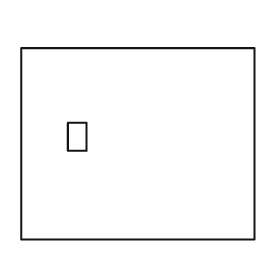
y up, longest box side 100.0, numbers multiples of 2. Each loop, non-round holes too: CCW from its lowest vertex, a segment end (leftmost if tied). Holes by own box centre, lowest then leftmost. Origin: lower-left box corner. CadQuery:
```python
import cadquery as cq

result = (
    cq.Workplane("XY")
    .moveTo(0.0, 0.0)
    .lineTo(100.0, 0.0)
    .lineTo(100.0, 82.0)
    .lineTo(0.0, 82.0)
    .close()
    .moveTo(20.0, 38.0)
    .lineTo(28.0, 38.0)
    .lineTo(28.0, 50.0)
    .lineTo(20.0, 50.0)
    .close()
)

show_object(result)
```